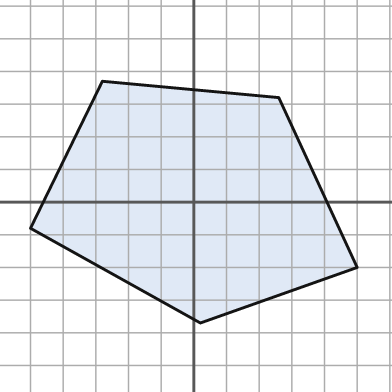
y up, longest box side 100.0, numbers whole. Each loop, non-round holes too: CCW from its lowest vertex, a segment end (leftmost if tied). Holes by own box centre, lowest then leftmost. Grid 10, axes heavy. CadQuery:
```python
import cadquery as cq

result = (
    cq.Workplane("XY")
    .moveTo(2.0, -37.0)
    .lineTo(50.0, -20.0)
    .lineTo(26.0, 32.0)
    .lineTo(-28.0, 37.0)
    .lineTo(-50.0, -8.0)
    .close()
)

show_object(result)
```